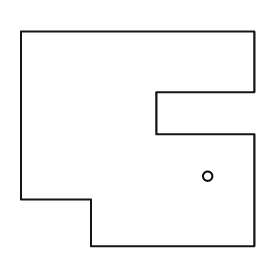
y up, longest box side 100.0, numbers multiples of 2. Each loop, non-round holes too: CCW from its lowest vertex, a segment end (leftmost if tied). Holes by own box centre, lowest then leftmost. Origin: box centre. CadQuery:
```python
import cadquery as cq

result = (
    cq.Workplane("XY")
    .moveTo(-20.0, -46.0)
    .lineTo(50.0, -46.0)
    .lineTo(50.0, 2.0)
    .lineTo(8.0, 2.0)
    .lineTo(8.0, 20.0)
    .lineTo(50.0, 20.0)
    .lineTo(50.0, 46.0)
    .lineTo(-50.0, 46.0)
    .lineTo(-50.0, -26.0)
    .lineTo(-20.0, -26.0)
    .close()
    .moveTo(30.0, -16.0)
    .circle(2.0)
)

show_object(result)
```